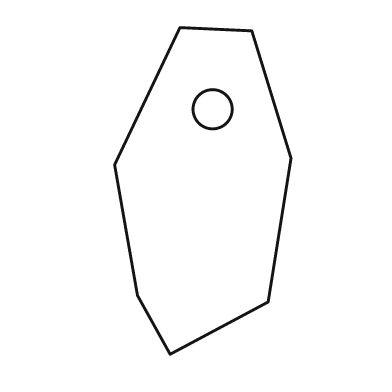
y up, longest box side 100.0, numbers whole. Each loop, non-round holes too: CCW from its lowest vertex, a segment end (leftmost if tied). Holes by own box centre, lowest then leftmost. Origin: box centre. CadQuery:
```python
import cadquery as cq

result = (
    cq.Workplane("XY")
    .moveTo(-10.0, -50.0)
    .lineTo(20.0, -34.0)
    .lineTo(27.0, 10.0)
    .lineTo(15.0, 49.0)
    .lineTo(-7.0, 50.0)
    .lineTo(-27.0, 8.0)
    .lineTo(-20.0, -32.0)
    .close()
    .moveTo(3.0, 25.0)
    .circle(6.0)
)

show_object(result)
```